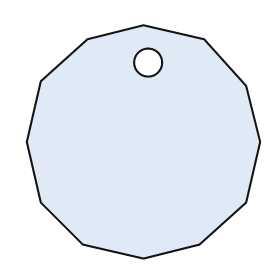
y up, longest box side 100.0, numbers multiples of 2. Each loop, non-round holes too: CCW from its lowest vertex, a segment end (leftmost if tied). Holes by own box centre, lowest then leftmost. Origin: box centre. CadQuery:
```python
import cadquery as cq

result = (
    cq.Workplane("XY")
    .moveTo(0.0, -50.0)
    .lineTo(24.0, -44.0)
    .lineTo(44.0, -26.0)
    .lineTo(50.0, 0.0)
    .lineTo(44.0, 24.0)
    .lineTo(26.0, 44.0)
    .lineTo(0.0, 50.0)
    .lineTo(-24.0, 44.0)
    .lineTo(-44.0, 26.0)
    .lineTo(-50.0, 0.0)
    .lineTo(-44.0, -26.0)
    .lineTo(-26.0, -44.0)
    .close()
    .moveTo(2.0, 34.0)
    .circle(6.0)
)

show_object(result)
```